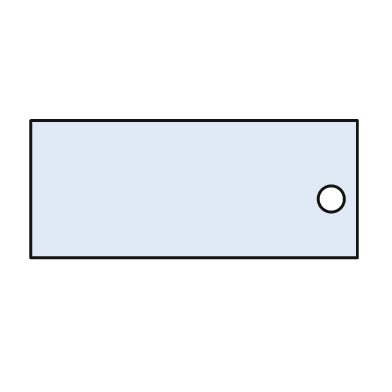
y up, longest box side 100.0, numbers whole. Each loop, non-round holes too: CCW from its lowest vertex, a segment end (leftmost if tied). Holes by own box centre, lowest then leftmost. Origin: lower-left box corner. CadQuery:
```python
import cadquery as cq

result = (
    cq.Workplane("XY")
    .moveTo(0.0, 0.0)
    .lineTo(100.0, 0.0)
    .lineTo(100.0, 42.0)
    .lineTo(0.0, 42.0)
    .close()
    .moveTo(92.0, 18.0)
    .circle(4.0)
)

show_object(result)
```